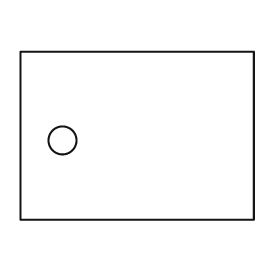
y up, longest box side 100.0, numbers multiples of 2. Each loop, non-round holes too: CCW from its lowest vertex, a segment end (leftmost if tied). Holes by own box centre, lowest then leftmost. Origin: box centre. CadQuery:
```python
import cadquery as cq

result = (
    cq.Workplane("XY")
    .moveTo(-50.0, -36.0)
    .lineTo(50.0, -36.0)
    .lineTo(50.0, 36.0)
    .lineTo(-50.0, 36.0)
    .close()
    .moveTo(-32.0, -2.0)
    .circle(6.0)
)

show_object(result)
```